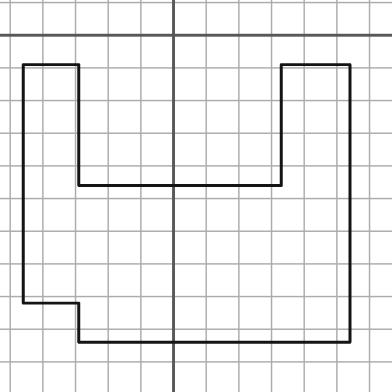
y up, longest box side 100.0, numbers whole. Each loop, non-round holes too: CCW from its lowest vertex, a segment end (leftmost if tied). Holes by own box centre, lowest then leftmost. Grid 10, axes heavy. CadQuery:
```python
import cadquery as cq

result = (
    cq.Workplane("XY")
    .moveTo(-29.0, -94.0)
    .lineTo(54.0, -94.0)
    .lineTo(54.0, -9.0)
    .lineTo(33.0, -9.0)
    .lineTo(33.0, -46.0)
    .lineTo(-29.0, -46.0)
    .lineTo(-29.0, -9.0)
    .lineTo(-46.0, -9.0)
    .lineTo(-46.0, -82.0)
    .lineTo(-29.0, -82.0)
    .close()
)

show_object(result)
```